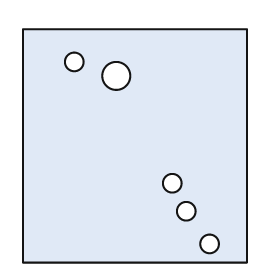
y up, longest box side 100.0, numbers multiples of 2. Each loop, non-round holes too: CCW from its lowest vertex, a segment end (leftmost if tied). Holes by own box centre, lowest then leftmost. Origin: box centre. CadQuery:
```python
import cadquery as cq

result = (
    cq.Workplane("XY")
    .moveTo(-48.0, -50.0)
    .lineTo(48.0, -50.0)
    .lineTo(48.0, 50.0)
    .lineTo(-48.0, 50.0)
    .close()
    .moveTo(32.0, -42.0)
    .circle(4.0)
    .moveTo(22.0, -28.0)
    .circle(4.0)
    .moveTo(16.0, -16.0)
    .circle(4.0)
    .moveTo(-8.0, 30.0)
    .circle(6.0)
    .moveTo(-26.0, 36.0)
    .circle(4.0)
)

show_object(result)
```